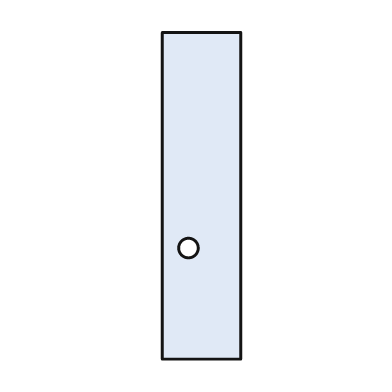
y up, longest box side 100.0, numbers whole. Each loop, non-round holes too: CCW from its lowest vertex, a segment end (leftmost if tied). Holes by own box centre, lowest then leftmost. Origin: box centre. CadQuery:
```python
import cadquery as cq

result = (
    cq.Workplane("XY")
    .moveTo(-12.0, -50.0)
    .lineTo(12.0, -50.0)
    .lineTo(12.0, 50.0)
    .lineTo(-12.0, 50.0)
    .close()
    .moveTo(-4.0, -16.0)
    .circle(3.0)
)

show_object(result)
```